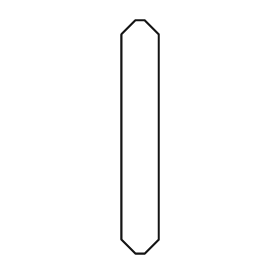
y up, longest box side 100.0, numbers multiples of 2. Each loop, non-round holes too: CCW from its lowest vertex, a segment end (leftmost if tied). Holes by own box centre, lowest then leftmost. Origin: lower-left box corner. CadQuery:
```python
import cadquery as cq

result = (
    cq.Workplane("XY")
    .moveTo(6.0, 0.0)
    .lineTo(10.0, 0.0)
    .lineTo(16.0, 6.0)
    .lineTo(16.0, 94.0)
    .lineTo(10.0, 100.0)
    .lineTo(6.0, 100.0)
    .lineTo(0.0, 94.0)
    .lineTo(0.0, 6.0)
    .close()
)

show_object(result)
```